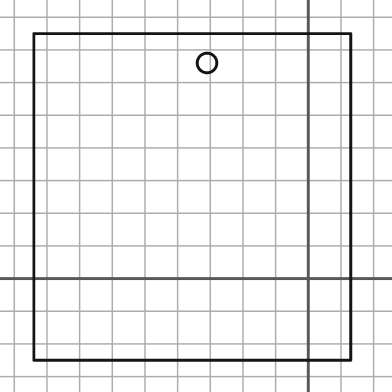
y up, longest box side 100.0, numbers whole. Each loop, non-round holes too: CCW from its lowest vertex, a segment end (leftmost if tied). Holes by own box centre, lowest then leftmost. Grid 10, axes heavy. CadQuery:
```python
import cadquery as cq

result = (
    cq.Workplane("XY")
    .moveTo(-84.0, -25.0)
    .lineTo(13.0, -25.0)
    .lineTo(13.0, 75.0)
    .lineTo(-84.0, 75.0)
    .close()
    .moveTo(-31.0, 66.0)
    .circle(3.0)
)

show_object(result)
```